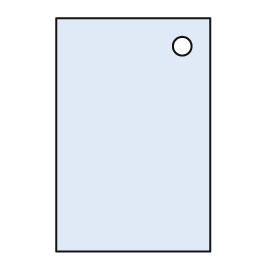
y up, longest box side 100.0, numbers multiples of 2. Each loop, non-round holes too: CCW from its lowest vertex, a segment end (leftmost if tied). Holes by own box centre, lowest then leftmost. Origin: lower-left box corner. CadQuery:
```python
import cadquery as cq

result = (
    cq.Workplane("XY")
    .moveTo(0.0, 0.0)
    .lineTo(66.0, 0.0)
    .lineTo(66.0, 100.0)
    .lineTo(0.0, 100.0)
    .close()
    .moveTo(54.0, 88.0)
    .circle(4.0)
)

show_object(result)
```